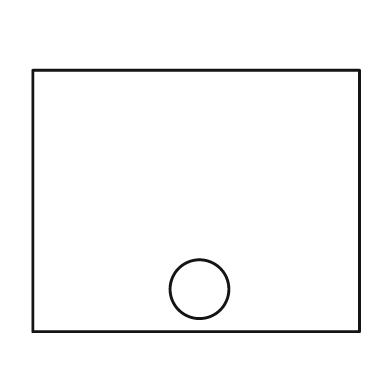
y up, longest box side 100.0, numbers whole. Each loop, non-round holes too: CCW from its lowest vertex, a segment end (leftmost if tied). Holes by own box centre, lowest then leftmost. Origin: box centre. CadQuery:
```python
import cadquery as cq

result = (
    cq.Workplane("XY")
    .moveTo(-50.0, -40.0)
    .lineTo(50.0, -40.0)
    .lineTo(50.0, 40.0)
    .lineTo(-50.0, 40.0)
    .close()
    .moveTo(1.0, -27.0)
    .circle(9.0)
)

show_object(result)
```